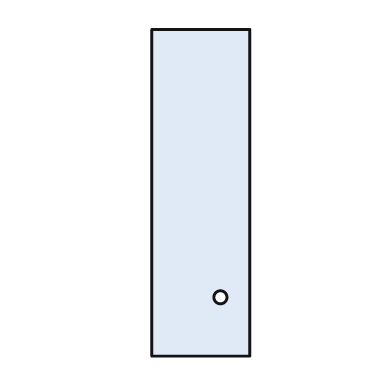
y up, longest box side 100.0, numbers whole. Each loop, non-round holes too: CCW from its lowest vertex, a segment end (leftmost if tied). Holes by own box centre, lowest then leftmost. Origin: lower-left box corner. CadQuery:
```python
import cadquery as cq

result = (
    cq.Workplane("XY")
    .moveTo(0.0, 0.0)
    .lineTo(30.0, 0.0)
    .lineTo(30.0, 100.0)
    .lineTo(0.0, 100.0)
    .close()
    .moveTo(21.0, 18.0)
    .circle(2.0)
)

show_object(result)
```